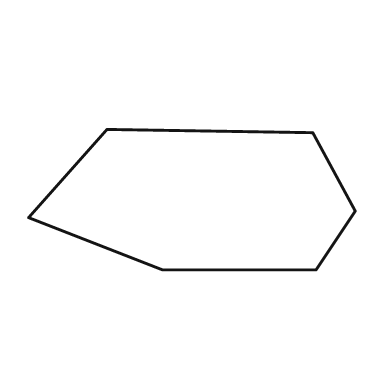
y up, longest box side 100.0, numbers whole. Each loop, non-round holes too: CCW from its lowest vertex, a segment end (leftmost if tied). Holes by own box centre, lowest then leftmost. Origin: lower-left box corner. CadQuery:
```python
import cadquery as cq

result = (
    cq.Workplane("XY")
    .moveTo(41.0, 0.0)
    .lineTo(88.0, 0.0)
    .lineTo(100.0, 18.0)
    .lineTo(87.0, 42.0)
    .lineTo(24.0, 43.0)
    .lineTo(0.0, 16.0)
    .close()
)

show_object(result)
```